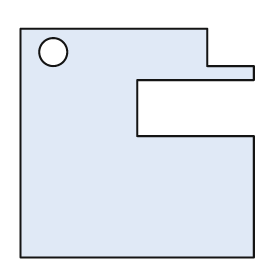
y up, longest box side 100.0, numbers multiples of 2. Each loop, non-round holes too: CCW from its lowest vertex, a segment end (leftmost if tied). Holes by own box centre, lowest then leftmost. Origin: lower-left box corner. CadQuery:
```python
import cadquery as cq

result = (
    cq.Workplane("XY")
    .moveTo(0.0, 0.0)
    .lineTo(100.0, 0.0)
    .lineTo(100.0, 52.0)
    .lineTo(50.0, 52.0)
    .lineTo(50.0, 76.0)
    .lineTo(100.0, 76.0)
    .lineTo(100.0, 82.0)
    .lineTo(80.0, 82.0)
    .lineTo(80.0, 98.0)
    .lineTo(0.0, 98.0)
    .close()
    .moveTo(14.0, 88.0)
    .circle(6.0)
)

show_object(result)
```